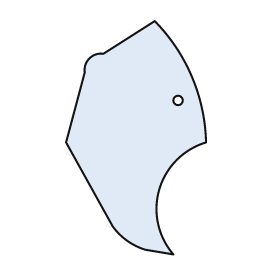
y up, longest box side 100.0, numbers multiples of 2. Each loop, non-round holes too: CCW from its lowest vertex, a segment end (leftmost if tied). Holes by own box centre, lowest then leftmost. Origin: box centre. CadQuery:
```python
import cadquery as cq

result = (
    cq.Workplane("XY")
    .moveTo(16.0, -50.0)
    .threePointArc((10.0, -22.0), (30.0, -2.0))
    .threePointArc((24.0, 26.0), (8.0, 50.0))
    .lineTo(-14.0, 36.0)
    .threePointArc((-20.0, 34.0), (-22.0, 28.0))
    .lineTo(-30.0, -2.0)
    .lineTo(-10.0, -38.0)
    .threePointArc((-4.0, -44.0), (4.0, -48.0))
    .close()
    .moveTo(18.0, 16.0)
    .circle(2.0)
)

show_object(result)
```